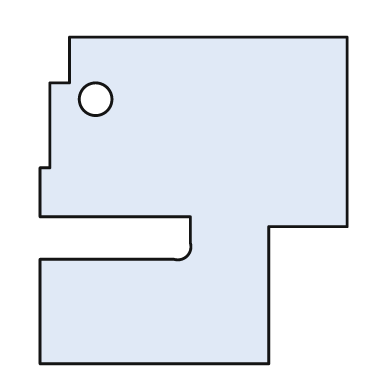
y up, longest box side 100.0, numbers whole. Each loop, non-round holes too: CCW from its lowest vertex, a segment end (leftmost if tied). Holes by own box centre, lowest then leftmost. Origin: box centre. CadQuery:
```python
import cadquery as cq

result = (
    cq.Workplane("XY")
    .moveTo(-47.0, -50.0)
    .lineTo(23.0, -50.0)
    .lineTo(23.0, -8.0)
    .lineTo(47.0, -8.0)
    .lineTo(47.0, 50.0)
    .lineTo(-38.0, 50.0)
    .lineTo(-38.0, 36.0)
    .lineTo(-44.0, 36.0)
    .lineTo(-44.0, 10.0)
    .lineTo(-47.0, 10.0)
    .lineTo(-47.0, -5.0)
    .lineTo(-1.0, -5.0)
    .lineTo(-1.0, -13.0)
    .threePointArc((-2.0, -17.0), (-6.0, -18.0))
    .lineTo(-47.0, -18.0)
    .close()
    .moveTo(-30.0, 31.0)
    .circle(5.0)
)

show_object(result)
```